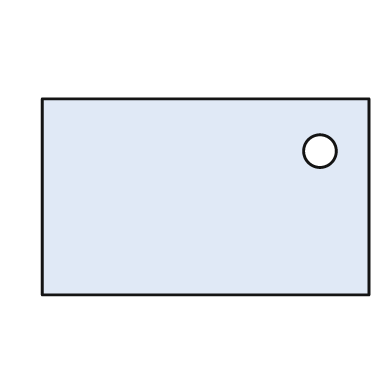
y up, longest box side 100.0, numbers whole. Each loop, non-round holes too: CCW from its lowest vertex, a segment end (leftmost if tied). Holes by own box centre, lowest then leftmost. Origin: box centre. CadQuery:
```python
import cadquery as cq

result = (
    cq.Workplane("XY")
    .moveTo(-50.0, -30.0)
    .lineTo(50.0, -30.0)
    .lineTo(50.0, 30.0)
    .lineTo(-50.0, 30.0)
    .close()
    .moveTo(35.0, 14.0)
    .circle(5.0)
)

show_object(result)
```